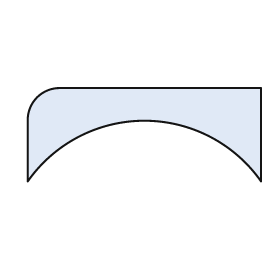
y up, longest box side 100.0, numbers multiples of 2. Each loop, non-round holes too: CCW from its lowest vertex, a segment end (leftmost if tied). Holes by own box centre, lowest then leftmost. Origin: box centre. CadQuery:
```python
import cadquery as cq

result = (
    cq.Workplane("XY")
    .moveTo(-50.0, -20.0)
    .threePointArc((0.0, 6.0), (50.0, -20.0))
    .lineTo(50.0, 20.0)
    .lineTo(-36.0, 20.0)
    .threePointArc((-46.0, 16.0), (-50.0, 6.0))
    .close()
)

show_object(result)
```